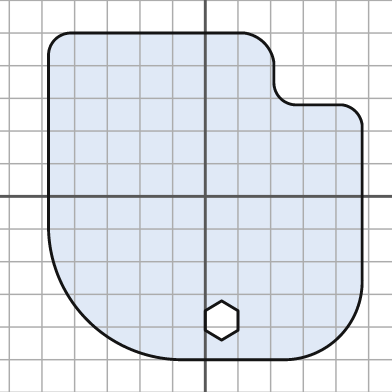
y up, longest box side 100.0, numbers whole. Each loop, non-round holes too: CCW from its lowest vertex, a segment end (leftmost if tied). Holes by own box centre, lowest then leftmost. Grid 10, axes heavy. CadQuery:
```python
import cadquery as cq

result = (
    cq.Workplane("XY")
    .moveTo(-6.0, -50.0)
    .lineTo(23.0, -50.0)
    .threePointArc((41.0, -43.0), (48.0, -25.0))
    .lineTo(48.0, 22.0)
    .threePointArc((46.0, 26.0), (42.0, 28.0))
    .lineTo(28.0, 28.0)
    .threePointArc((23.0, 30.0), (21.0, 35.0))
    .lineTo(21.0, 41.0)
    .threePointArc((18.0, 47.0), (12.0, 50.0))
    .lineTo(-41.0, 50.0)
    .threePointArc((-46.0, 48.0), (-48.0, 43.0))
    .lineTo(-48.0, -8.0)
    .threePointArc((-36.0, -38.0), (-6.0, -50.0))
    .close()
    .moveTo(5.0, -44.0)
    .lineTo(10.0, -41.0)
    .lineTo(10.0, -35.0)
    .lineTo(5.0, -32.0)
    .lineTo(0.0, -35.0)
    .lineTo(0.0, -41.0)
    .close()
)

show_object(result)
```